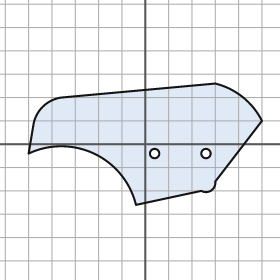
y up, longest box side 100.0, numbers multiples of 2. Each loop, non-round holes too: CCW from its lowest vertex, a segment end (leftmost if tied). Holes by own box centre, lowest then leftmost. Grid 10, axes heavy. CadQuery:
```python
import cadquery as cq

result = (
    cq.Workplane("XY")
    .moveTo(-4.0, -26.0)
    .lineTo(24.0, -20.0)
    .threePointArc((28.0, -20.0), (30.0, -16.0))
    .lineTo(50.0, 10.0)
    .threePointArc((42.0, 20.0), (30.0, 26.0))
    .lineTo(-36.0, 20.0)
    .threePointArc((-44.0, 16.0), (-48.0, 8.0))
    .lineTo(-50.0, -4.0)
    .threePointArc((-22.0, -4.0), (-4.0, -26.0))
    .close()
    .moveTo(4.0, -4.0)
    .circle(2.0)
    .moveTo(26.0, -4.0)
    .circle(2.0)
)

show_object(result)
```